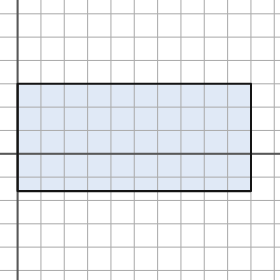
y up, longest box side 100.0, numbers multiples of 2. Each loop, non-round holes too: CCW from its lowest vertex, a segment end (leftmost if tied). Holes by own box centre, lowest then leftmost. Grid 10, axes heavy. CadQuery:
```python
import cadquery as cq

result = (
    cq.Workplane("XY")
    .moveTo(0.0, -16.0)
    .lineTo(100.0, -16.0)
    .lineTo(100.0, 30.0)
    .lineTo(0.0, 30.0)
    .close()
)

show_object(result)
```